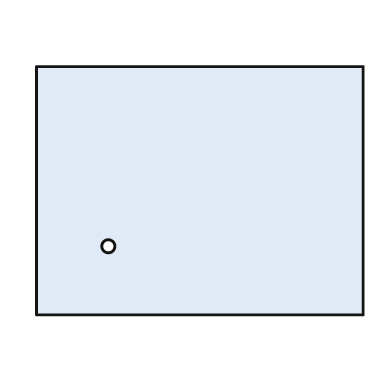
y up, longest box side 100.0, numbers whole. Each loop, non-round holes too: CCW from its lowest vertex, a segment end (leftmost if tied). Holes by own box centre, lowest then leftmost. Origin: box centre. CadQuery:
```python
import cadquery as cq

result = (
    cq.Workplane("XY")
    .moveTo(-50.0, -38.0)
    .lineTo(50.0, -38.0)
    .lineTo(50.0, 38.0)
    .lineTo(-50.0, 38.0)
    .close()
    .moveTo(-28.0, -17.0)
    .circle(2.0)
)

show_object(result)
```